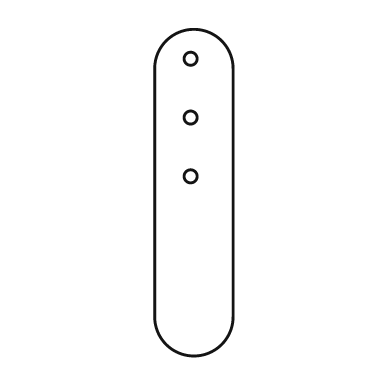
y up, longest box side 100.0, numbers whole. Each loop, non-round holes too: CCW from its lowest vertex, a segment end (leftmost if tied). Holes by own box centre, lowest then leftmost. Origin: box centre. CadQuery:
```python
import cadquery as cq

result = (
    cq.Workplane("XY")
    .moveTo(-12.0, -38.0)
    .threePointArc((0.0, -50.0), (12.0, -38.0))
    .lineTo(12.0, 38.0)
    .threePointArc((0.0, 50.0), (-12.0, 38.0))
    .close()
    .moveTo(-1.0, 5.0)
    .circle(2.0)
    .moveTo(-1.0, 23.0)
    .circle(2.0)
    .moveTo(-1.0, 41.0)
    .circle(2.0)
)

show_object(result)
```